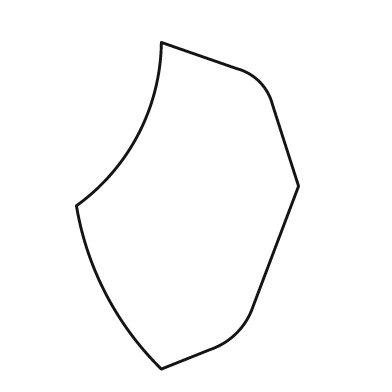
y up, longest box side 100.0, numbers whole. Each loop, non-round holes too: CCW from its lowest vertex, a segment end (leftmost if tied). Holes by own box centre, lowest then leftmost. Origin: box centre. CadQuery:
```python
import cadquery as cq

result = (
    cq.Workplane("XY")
    .moveTo(-8.0, -50.0)
    .lineTo(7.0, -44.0)
    .threePointArc((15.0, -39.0), (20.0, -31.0))
    .lineTo(34.0, 6.0)
    .lineTo(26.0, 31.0)
    .threePointArc((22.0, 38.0), (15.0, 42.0))
    .lineTo(-8.0, 50.0)
    .threePointArc((-15.0, 22.0), (-34.0, 0.0))
    .threePointArc((-25.0, -27.0), (-8.0, -50.0))
    .close()
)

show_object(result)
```